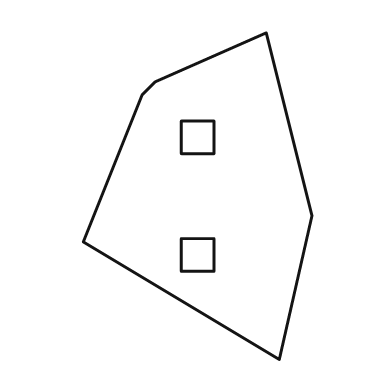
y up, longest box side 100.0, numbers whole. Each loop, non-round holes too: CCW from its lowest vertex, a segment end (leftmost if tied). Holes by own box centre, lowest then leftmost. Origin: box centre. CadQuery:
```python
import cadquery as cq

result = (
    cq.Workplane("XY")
    .moveTo(25.0, -50.0)
    .lineTo(35.0, -6.0)
    .lineTo(21.0, 50.0)
    .lineTo(-13.0, 35.0)
    .lineTo(-17.0, 31.0)
    .lineTo(-35.0, -14.0)
    .close()
    .moveTo(-5.0, -23.0)
    .lineTo(5.0, -23.0)
    .lineTo(5.0, -13.0)
    .lineTo(-5.0, -13.0)
    .close()
    .moveTo(-5.0, 13.0)
    .lineTo(5.0, 13.0)
    .lineTo(5.0, 23.0)
    .lineTo(-5.0, 23.0)
    .close()
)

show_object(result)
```